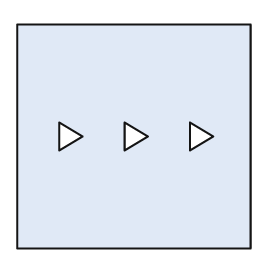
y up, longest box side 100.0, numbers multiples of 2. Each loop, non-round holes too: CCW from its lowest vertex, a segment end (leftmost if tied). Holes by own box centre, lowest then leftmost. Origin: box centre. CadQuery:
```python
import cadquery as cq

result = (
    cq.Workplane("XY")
    .moveTo(-50.0, -48.0)
    .lineTo(50.0, -48.0)
    .lineTo(50.0, 48.0)
    .lineTo(-50.0, 48.0)
    .close()
    .moveTo(-32.0, -6.0)
    .lineTo(-22.0, 0.0)
    .lineTo(-32.0, 6.0)
    .close()
    .moveTo(-4.0, -6.0)
    .lineTo(6.0, 0.0)
    .lineTo(-4.0, 6.0)
    .close()
    .moveTo(24.0, -6.0)
    .lineTo(34.0, 0.0)
    .lineTo(24.0, 6.0)
    .close()
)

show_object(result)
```